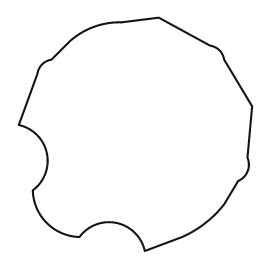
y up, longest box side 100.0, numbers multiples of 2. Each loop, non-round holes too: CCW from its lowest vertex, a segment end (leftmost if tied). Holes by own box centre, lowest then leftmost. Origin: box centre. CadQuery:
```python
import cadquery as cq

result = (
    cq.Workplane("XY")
    .moveTo(4.0, -50.0)
    .lineTo(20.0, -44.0)
    .threePointArc((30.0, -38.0), (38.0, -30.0))
    .lineTo(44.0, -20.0)
    .threePointArc((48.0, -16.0), (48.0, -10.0))
    .lineTo(50.0, 12.0)
    .lineTo(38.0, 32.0)
    .threePointArc((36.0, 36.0), (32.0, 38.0))
    .lineTo(10.0, 50.0)
    .lineTo(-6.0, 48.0)
    .threePointArc((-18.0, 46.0), (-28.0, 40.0))
    .lineTo(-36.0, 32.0)
    .threePointArc((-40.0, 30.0), (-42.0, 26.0))
    .lineTo(-50.0, 4.0)
    .threePointArc((-38.0, -8.0), (-44.0, -24.0))
    .threePointArc((-38.0, -38.0), (-24.0, -44.0))
    .threePointArc((-8.0, -38.0), (4.0, -50.0))
    .close()
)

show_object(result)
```